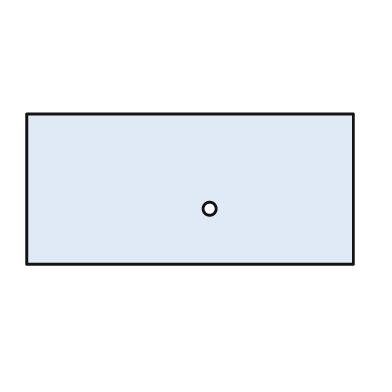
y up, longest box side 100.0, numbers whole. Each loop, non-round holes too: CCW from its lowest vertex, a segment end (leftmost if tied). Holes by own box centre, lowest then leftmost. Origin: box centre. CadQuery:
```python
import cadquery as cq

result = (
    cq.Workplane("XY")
    .moveTo(-50.0, -23.0)
    .lineTo(50.0, -23.0)
    .lineTo(50.0, 23.0)
    .lineTo(-50.0, 23.0)
    .close()
    .moveTo(6.0, -6.0)
    .circle(2.0)
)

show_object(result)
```